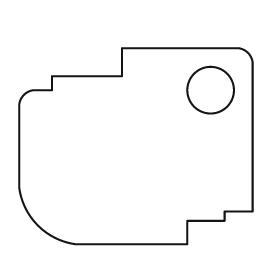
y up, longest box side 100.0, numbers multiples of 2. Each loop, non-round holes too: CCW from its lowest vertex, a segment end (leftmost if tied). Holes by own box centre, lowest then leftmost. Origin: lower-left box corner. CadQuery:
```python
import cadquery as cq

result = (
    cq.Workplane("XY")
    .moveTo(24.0, 0.0)
    .lineTo(72.0, 0.0)
    .lineTo(72.0, 10.0)
    .lineTo(88.0, 10.0)
    .lineTo(88.0, 14.0)
    .lineTo(100.0, 14.0)
    .lineTo(100.0, 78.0)
    .threePointArc((98.0, 82.0), (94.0, 84.0))
    .lineTo(44.0, 84.0)
    .lineTo(44.0, 72.0)
    .lineTo(14.0, 72.0)
    .lineTo(14.0, 66.0)
    .lineTo(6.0, 66.0)
    .threePointArc((2.0, 64.0), (0.0, 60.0))
    .lineTo(0.0, 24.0)
    .threePointArc((8.0, 8.0), (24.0, 0.0))
    .close()
    .moveTo(82.0, 66.0)
    .circle(10.0)
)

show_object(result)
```